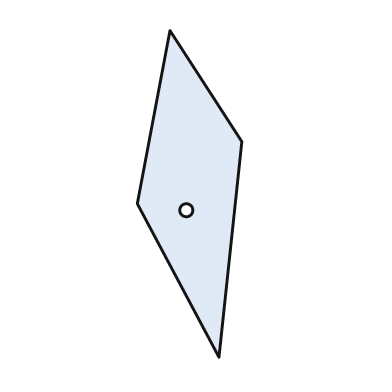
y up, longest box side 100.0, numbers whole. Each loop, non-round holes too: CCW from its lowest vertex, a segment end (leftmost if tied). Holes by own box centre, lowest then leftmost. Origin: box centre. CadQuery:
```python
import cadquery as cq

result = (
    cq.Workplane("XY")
    .moveTo(9.0, -50.0)
    .lineTo(16.0, 16.0)
    .lineTo(-6.0, 50.0)
    .lineTo(-16.0, -3.0)
    .close()
    .moveTo(-1.0, -5.0)
    .circle(2.0)
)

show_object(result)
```